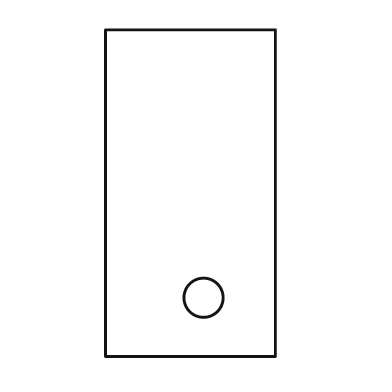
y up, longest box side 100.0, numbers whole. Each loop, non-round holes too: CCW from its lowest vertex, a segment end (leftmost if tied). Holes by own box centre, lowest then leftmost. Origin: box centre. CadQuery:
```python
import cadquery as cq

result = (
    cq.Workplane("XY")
    .moveTo(-26.0, -50.0)
    .lineTo(26.0, -50.0)
    .lineTo(26.0, 50.0)
    .lineTo(-26.0, 50.0)
    .close()
    .moveTo(4.0, -32.0)
    .circle(6.0)
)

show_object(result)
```